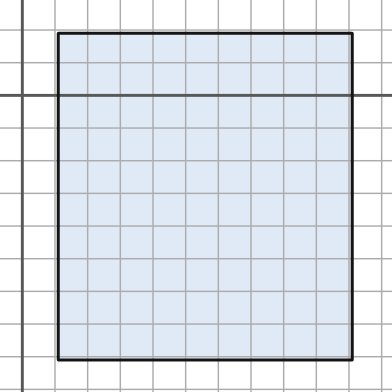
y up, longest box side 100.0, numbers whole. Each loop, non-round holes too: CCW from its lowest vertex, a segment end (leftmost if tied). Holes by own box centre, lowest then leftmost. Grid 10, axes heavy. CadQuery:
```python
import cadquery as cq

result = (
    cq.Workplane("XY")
    .moveTo(11.0, -81.0)
    .lineTo(101.0, -81.0)
    .lineTo(101.0, 19.0)
    .lineTo(11.0, 19.0)
    .close()
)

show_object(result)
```